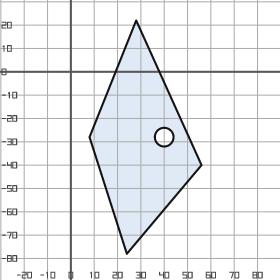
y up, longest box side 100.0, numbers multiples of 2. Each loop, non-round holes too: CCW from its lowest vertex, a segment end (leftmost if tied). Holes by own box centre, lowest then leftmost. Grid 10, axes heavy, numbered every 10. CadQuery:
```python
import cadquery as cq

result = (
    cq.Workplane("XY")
    .moveTo(24.0, -78.0)
    .lineTo(56.0, -40.0)
    .lineTo(28.0, 22.0)
    .lineTo(8.0, -28.0)
    .close()
    .moveTo(40.0, -28.0)
    .circle(4.0)
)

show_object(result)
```